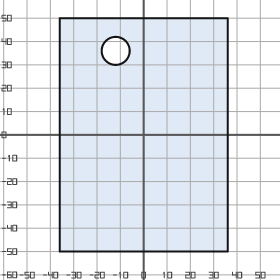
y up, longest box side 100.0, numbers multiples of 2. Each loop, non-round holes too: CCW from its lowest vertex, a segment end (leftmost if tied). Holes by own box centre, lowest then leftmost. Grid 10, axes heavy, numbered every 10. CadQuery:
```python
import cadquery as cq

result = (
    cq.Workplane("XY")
    .moveTo(-36.0, -50.0)
    .lineTo(36.0, -50.0)
    .lineTo(36.0, 50.0)
    .lineTo(-36.0, 50.0)
    .close()
    .moveTo(-12.0, 36.0)
    .circle(6.0)
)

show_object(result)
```